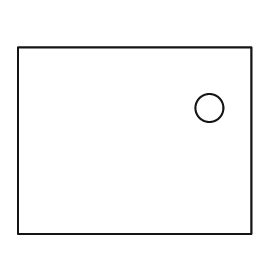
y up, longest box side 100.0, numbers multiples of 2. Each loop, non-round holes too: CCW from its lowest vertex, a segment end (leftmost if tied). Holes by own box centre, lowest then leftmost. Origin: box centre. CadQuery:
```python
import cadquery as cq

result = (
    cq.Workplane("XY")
    .moveTo(-50.0, -40.0)
    .lineTo(50.0, -40.0)
    .lineTo(50.0, 40.0)
    .lineTo(-50.0, 40.0)
    .close()
    .moveTo(32.0, 14.0)
    .circle(6.0)
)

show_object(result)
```